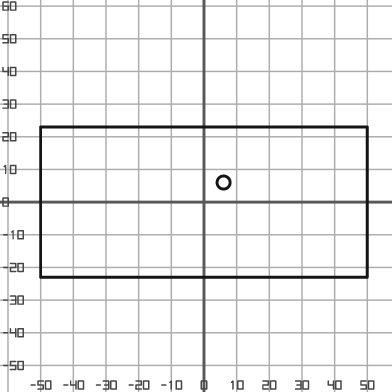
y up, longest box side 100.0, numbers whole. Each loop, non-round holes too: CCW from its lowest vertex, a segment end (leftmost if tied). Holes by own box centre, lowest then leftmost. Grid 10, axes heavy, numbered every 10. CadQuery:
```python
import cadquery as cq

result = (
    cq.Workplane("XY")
    .moveTo(-50.0, -23.0)
    .lineTo(50.0, -23.0)
    .lineTo(50.0, 23.0)
    .lineTo(-50.0, 23.0)
    .close()
    .moveTo(6.0, 6.0)
    .circle(2.0)
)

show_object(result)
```